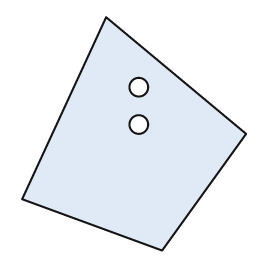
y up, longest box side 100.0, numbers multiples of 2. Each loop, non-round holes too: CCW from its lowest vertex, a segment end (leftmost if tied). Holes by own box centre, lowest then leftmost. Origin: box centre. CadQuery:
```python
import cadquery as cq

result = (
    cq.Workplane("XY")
    .moveTo(12.0, -50.0)
    .lineTo(48.0, 0.0)
    .lineTo(-12.0, 50.0)
    .lineTo(-48.0, -28.0)
    .close()
    .moveTo(2.0, 4.0)
    .circle(4.0)
    .moveTo(2.0, 20.0)
    .circle(4.0)
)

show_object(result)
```